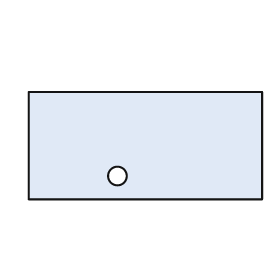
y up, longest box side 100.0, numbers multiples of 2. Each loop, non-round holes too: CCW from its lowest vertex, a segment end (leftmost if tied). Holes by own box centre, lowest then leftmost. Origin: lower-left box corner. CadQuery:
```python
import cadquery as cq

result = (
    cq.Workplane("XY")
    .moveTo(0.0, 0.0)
    .lineTo(100.0, 0.0)
    .lineTo(100.0, 46.0)
    .lineTo(0.0, 46.0)
    .close()
    .moveTo(38.0, 10.0)
    .circle(4.0)
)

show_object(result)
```